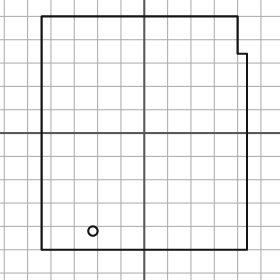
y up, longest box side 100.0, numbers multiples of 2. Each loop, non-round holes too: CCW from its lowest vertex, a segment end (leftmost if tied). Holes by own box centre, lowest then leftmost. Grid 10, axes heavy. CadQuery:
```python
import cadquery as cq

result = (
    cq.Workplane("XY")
    .moveTo(-44.0, -50.0)
    .lineTo(44.0, -50.0)
    .lineTo(44.0, 34.0)
    .lineTo(40.0, 34.0)
    .lineTo(40.0, 50.0)
    .lineTo(-44.0, 50.0)
    .close()
    .moveTo(-22.0, -42.0)
    .circle(2.0)
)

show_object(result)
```